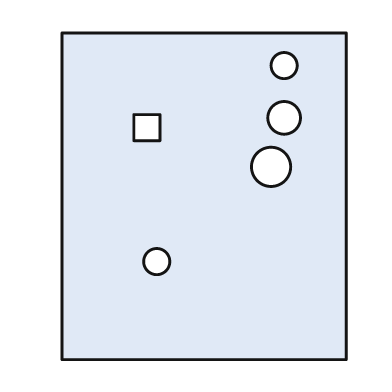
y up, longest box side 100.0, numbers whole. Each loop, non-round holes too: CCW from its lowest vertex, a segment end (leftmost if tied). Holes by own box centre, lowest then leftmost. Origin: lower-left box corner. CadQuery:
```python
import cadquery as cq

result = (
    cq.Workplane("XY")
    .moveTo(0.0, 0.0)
    .lineTo(87.0, 0.0)
    .lineTo(87.0, 100.0)
    .lineTo(0.0, 100.0)
    .close()
    .moveTo(29.0, 30.0)
    .circle(4.0)
    .moveTo(64.0, 59.0)
    .circle(6.0)
    .moveTo(22.0, 67.0)
    .lineTo(30.0, 67.0)
    .lineTo(30.0, 75.0)
    .lineTo(22.0, 75.0)
    .close()
    .moveTo(68.0, 74.0)
    .circle(5.0)
    .moveTo(68.0, 90.0)
    .circle(4.0)
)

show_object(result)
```